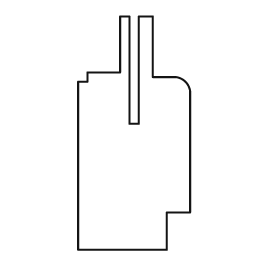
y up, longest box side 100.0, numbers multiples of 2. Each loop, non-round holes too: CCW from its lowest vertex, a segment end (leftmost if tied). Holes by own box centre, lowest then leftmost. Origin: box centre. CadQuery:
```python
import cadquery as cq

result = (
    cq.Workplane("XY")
    .moveTo(-24.0, -50.0)
    .lineTo(14.0, -50.0)
    .lineTo(14.0, -34.0)
    .lineTo(24.0, -34.0)
    .lineTo(24.0, 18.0)
    .threePointArc((22.0, 22.0), (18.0, 24.0))
    .lineTo(8.0, 24.0)
    .lineTo(8.0, 50.0)
    .lineTo(2.0, 50.0)
    .lineTo(2.0, 4.0)
    .lineTo(-2.0, 4.0)
    .lineTo(-2.0, 50.0)
    .lineTo(-6.0, 50.0)
    .lineTo(-6.0, 26.0)
    .lineTo(-20.0, 26.0)
    .lineTo(-20.0, 22.0)
    .lineTo(-24.0, 22.0)
    .close()
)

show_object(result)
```